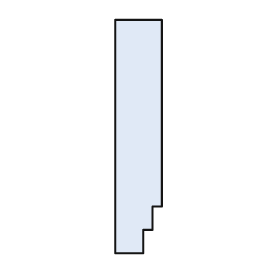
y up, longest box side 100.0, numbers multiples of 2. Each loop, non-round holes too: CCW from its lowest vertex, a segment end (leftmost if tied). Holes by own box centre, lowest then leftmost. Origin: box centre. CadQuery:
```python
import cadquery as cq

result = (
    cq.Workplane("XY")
    .moveTo(-10.0, -50.0)
    .lineTo(2.0, -50.0)
    .lineTo(2.0, -40.0)
    .lineTo(6.0, -40.0)
    .lineTo(6.0, -30.0)
    .lineTo(10.0, -30.0)
    .lineTo(10.0, 50.0)
    .lineTo(-10.0, 50.0)
    .close()
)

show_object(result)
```